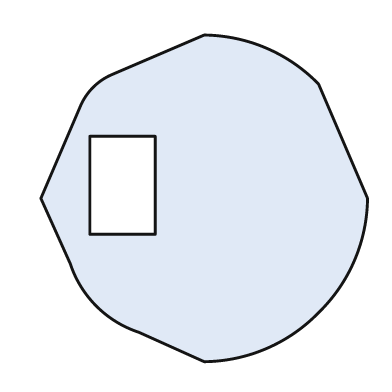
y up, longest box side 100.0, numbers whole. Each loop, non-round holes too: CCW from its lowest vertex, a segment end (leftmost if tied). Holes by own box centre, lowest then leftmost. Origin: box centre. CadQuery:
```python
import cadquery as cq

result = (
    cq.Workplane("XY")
    .moveTo(0.0, -50.0)
    .threePointArc((19.0, -46.0), (35.0, -35.0))
    .threePointArc((46.0, -19.0), (50.0, 0.0))
    .lineTo(35.0, 35.0)
    .threePointArc((19.0, 46.0), (0.0, 50.0))
    .lineTo(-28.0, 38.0)
    .threePointArc((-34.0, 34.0), (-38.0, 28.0))
    .lineTo(-50.0, 0.0)
    .lineTo(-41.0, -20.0)
    .threePointArc((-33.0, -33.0), (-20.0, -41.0))
    .close()
    .moveTo(-35.0, -11.0)
    .lineTo(-15.0, -11.0)
    .lineTo(-15.0, 19.0)
    .lineTo(-35.0, 19.0)
    .close()
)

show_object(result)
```